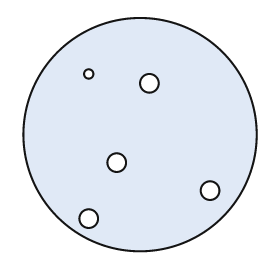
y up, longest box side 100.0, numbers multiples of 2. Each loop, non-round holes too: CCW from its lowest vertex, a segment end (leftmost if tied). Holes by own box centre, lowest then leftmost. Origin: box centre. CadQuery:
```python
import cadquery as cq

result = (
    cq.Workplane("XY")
    .moveTo(0.0, 0.0)
    .circle(50.0)
    .moveTo(-22.0, -36.0)
    .circle(4.0)
    .moveTo(30.0, -24.0)
    .circle(4.0)
    .moveTo(-10.0, -12.0)
    .circle(4.0)
    .moveTo(4.0, 22.0)
    .circle(4.0)
    .moveTo(-22.0, 26.0)
    .circle(2.0)
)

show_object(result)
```